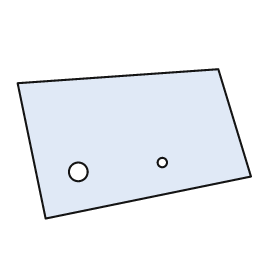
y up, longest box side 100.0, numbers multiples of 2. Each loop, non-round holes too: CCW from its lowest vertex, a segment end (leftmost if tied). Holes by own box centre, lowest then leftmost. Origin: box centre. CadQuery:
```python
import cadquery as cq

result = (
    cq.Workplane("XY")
    .moveTo(-38.0, -32.0)
    .lineTo(50.0, -14.0)
    .lineTo(36.0, 32.0)
    .lineTo(-50.0, 26.0)
    .close()
    .moveTo(-24.0, -12.0)
    .circle(4.0)
    .moveTo(12.0, -8.0)
    .circle(2.0)
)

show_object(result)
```